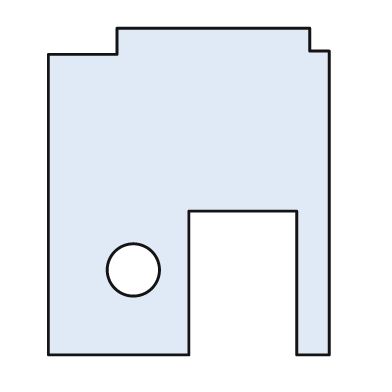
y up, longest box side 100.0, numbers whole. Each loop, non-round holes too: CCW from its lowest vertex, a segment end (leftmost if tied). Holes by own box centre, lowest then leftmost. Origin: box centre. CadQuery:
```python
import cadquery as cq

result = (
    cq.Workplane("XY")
    .moveTo(-43.0, -50.0)
    .lineTo(0.0, -50.0)
    .lineTo(0.0, -6.0)
    .lineTo(33.0, -6.0)
    .lineTo(33.0, -50.0)
    .lineTo(43.0, -50.0)
    .lineTo(43.0, 43.0)
    .lineTo(37.0, 43.0)
    .lineTo(37.0, 50.0)
    .lineTo(-22.0, 50.0)
    .lineTo(-22.0, 42.0)
    .lineTo(-43.0, 42.0)
    .close()
    .moveTo(-17.0, -24.0)
    .circle(8.0)
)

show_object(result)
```